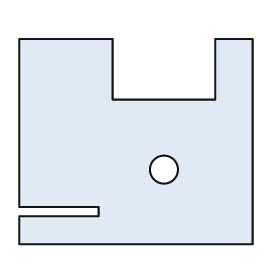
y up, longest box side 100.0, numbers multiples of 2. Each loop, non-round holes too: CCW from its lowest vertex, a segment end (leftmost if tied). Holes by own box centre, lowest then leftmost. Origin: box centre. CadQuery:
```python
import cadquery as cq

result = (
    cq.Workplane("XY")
    .moveTo(-50.0, -44.0)
    .lineTo(50.0, -44.0)
    .lineTo(50.0, 44.0)
    .lineTo(34.0, 44.0)
    .lineTo(34.0, 18.0)
    .lineTo(-10.0, 18.0)
    .lineTo(-10.0, 44.0)
    .lineTo(-50.0, 44.0)
    .lineTo(-50.0, -28.0)
    .lineTo(-16.0, -28.0)
    .lineTo(-16.0, -32.0)
    .lineTo(-50.0, -32.0)
    .close()
    .moveTo(12.0, -12.0)
    .circle(6.0)
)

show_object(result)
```